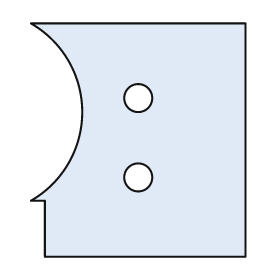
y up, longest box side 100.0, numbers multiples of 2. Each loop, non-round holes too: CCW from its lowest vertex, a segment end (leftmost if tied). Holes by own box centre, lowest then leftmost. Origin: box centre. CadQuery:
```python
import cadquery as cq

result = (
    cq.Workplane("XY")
    .moveTo(-40.0, -50.0)
    .lineTo(46.0, -50.0)
    .lineTo(46.0, 50.0)
    .lineTo(-46.0, 50.0)
    .threePointArc((-24.0, 12.0), (-46.0, -26.0))
    .lineTo(-40.0, -26.0)
    .close()
    .moveTo(0.0, -16.0)
    .circle(6.0)
    .moveTo(0.0, 18.0)
    .circle(6.0)
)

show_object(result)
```